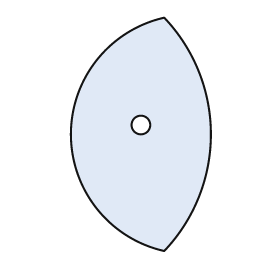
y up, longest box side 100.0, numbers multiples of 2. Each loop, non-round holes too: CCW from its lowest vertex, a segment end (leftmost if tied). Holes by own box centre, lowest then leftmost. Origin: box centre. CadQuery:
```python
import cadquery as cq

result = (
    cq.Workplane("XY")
    .moveTo(10.0, -50.0)
    .threePointArc((30.0, 0.0), (10.0, 50.0))
    .threePointArc((-30.0, 0.0), (10.0, -50.0))
    .close()
    .moveTo(0.0, 4.0)
    .circle(4.0)
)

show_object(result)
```